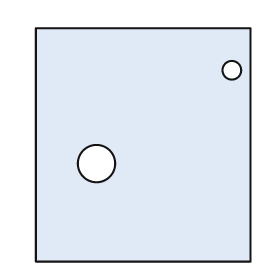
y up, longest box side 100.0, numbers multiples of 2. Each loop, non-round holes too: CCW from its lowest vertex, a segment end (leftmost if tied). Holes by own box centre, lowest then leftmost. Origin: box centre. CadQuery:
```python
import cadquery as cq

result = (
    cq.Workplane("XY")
    .moveTo(-46.0, -50.0)
    .lineTo(46.0, -50.0)
    .lineTo(46.0, 50.0)
    .lineTo(-46.0, 50.0)
    .close()
    .moveTo(-20.0, -8.0)
    .circle(8.0)
    .moveTo(38.0, 32.0)
    .circle(4.0)
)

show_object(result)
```